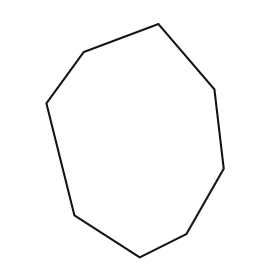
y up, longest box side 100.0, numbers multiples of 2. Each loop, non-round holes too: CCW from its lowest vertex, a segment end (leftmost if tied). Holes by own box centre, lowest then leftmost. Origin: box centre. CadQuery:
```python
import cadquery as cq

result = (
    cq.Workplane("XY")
    .moveTo(2.0, -50.0)
    .lineTo(22.0, -40.0)
    .lineTo(38.0, -12.0)
    .lineTo(34.0, 22.0)
    .lineTo(10.0, 50.0)
    .lineTo(-22.0, 38.0)
    .lineTo(-38.0, 16.0)
    .lineTo(-26.0, -32.0)
    .close()
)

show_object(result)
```